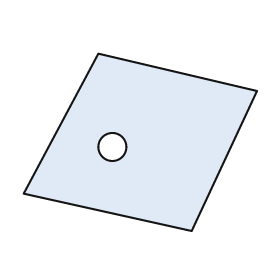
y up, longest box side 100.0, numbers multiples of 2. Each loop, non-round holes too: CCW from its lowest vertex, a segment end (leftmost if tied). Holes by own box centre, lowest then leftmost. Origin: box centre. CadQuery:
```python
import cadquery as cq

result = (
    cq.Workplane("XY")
    .moveTo(22.0, -38.0)
    .lineTo(50.0, 22.0)
    .lineTo(-18.0, 38.0)
    .lineTo(-50.0, -22.0)
    .close()
    .moveTo(-12.0, -2.0)
    .circle(6.0)
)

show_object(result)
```